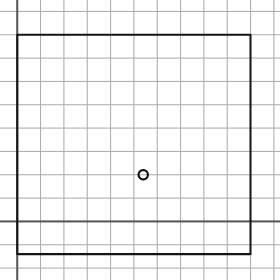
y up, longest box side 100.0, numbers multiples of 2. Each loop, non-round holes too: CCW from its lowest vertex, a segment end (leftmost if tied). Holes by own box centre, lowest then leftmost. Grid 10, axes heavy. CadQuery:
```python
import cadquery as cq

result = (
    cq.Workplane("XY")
    .moveTo(0.0, -14.0)
    .lineTo(100.0, -14.0)
    .lineTo(100.0, 80.0)
    .lineTo(0.0, 80.0)
    .close()
    .moveTo(54.0, 20.0)
    .circle(2.0)
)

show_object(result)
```